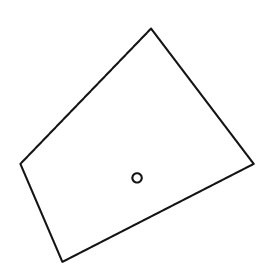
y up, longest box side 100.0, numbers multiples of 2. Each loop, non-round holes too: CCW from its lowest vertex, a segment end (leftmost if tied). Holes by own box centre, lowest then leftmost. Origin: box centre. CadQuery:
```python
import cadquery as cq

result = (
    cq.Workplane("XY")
    .moveTo(-32.0, -50.0)
    .lineTo(50.0, -8.0)
    .lineTo(6.0, 50.0)
    .lineTo(-50.0, -8.0)
    .close()
    .moveTo(0.0, -14.0)
    .circle(2.0)
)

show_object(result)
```